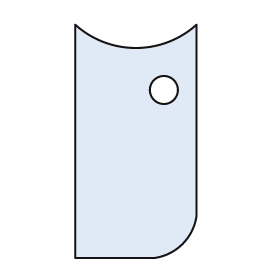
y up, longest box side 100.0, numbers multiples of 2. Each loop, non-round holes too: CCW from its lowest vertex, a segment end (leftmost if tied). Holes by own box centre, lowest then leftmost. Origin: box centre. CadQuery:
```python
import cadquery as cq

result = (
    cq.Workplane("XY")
    .moveTo(-26.0, -50.0)
    .lineTo(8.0, -50.0)
    .threePointArc((20.0, -44.0), (26.0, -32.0))
    .lineTo(26.0, 50.0)
    .threePointArc((0.0, 40.0), (-26.0, 50.0))
    .close()
    .moveTo(12.0, 22.0)
    .circle(6.0)
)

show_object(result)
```